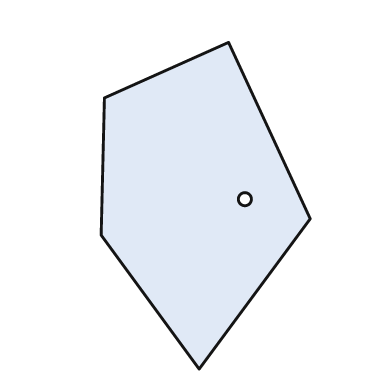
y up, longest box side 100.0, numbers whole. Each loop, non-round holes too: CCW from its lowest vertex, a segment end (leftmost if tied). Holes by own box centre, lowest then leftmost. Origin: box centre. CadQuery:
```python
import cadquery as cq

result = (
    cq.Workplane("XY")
    .moveTo(-2.0, -50.0)
    .lineTo(32.0, -4.0)
    .lineTo(7.0, 50.0)
    .lineTo(-31.0, 33.0)
    .lineTo(-32.0, -9.0)
    .close()
    .moveTo(12.0, 2.0)
    .circle(2.0)
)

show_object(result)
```